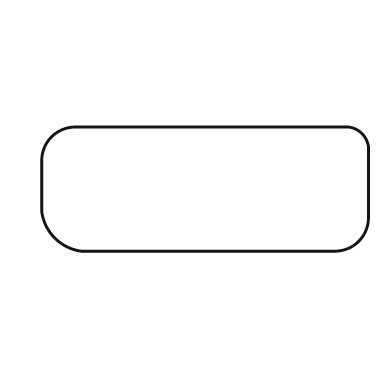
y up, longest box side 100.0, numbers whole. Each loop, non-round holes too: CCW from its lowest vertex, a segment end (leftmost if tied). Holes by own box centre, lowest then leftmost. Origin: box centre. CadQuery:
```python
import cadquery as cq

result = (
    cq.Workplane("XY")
    .moveTo(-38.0, -19.0)
    .lineTo(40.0, -19.0)
    .threePointArc((47.0, -16.0), (50.0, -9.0))
    .lineTo(50.0, 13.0)
    .threePointArc((48.0, 17.0), (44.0, 19.0))
    .lineTo(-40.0, 19.0)
    .threePointArc((-47.0, 16.0), (-50.0, 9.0))
    .lineTo(-50.0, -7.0)
    .threePointArc((-46.0, -15.0), (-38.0, -19.0))
    .close()
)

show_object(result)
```